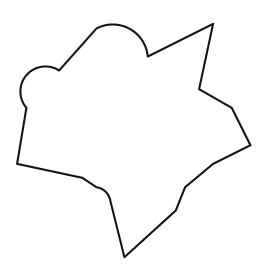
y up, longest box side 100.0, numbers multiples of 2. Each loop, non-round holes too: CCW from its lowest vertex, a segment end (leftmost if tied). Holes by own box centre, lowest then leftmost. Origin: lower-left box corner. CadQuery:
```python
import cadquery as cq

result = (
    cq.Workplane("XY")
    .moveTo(46.0, 0.0)
    .lineTo(68.0, 20.0)
    .lineTo(72.0, 30.0)
    .lineTo(84.0, 40.0)
    .lineTo(100.0, 48.0)
    .lineTo(92.0, 64.0)
    .lineTo(78.0, 72.0)
    .lineTo(84.0, 100.0)
    .lineTo(56.0, 86.0)
    .threePointArc((48.0, 98.0), (34.0, 98.0))
    .lineTo(18.0, 80.0)
    .threePointArc((4.0, 78.0), (4.0, 64.0))
    .lineTo(0.0, 40.0)
    .lineTo(28.0, 34.0)
    .lineTo(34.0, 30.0)
    .threePointArc((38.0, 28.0), (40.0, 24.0))
    .close()
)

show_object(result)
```